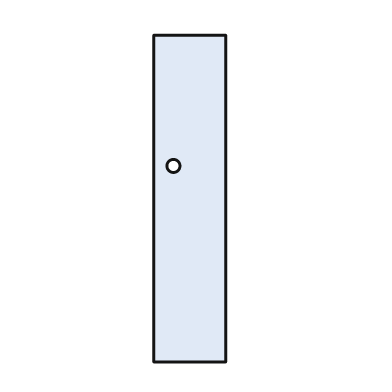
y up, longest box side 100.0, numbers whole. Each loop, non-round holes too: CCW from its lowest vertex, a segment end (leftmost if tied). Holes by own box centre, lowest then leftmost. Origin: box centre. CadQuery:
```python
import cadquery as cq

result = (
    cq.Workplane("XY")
    .moveTo(-11.0, -50.0)
    .lineTo(11.0, -50.0)
    .lineTo(11.0, 50.0)
    .lineTo(-11.0, 50.0)
    .close()
    .moveTo(-5.0, 10.0)
    .circle(2.0)
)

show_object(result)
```